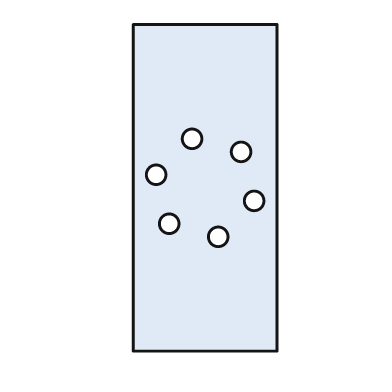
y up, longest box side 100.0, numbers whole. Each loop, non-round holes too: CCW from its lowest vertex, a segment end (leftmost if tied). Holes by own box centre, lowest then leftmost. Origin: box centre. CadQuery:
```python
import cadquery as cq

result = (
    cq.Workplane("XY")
    .moveTo(-22.0, -50.0)
    .lineTo(22.0, -50.0)
    .lineTo(22.0, 50.0)
    .lineTo(-22.0, 50.0)
    .close()
    .moveTo(4.0, -15.0)
    .circle(3.0)
    .moveTo(-11.0, -11.0)
    .circle(3.0)
    .moveTo(15.0, -4.0)
    .circle(3.0)
    .moveTo(-15.0, 4.0)
    .circle(3.0)
    .moveTo(11.0, 11.0)
    .circle(3.0)
    .moveTo(-4.0, 15.0)
    .circle(3.0)
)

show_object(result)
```